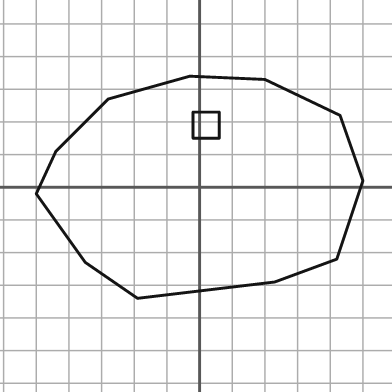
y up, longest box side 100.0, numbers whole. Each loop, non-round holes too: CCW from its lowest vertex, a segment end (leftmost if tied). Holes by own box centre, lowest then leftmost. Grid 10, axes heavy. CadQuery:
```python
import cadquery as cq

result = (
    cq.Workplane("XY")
    .moveTo(-19.0, -34.0)
    .lineTo(23.0, -29.0)
    .lineTo(42.0, -22.0)
    .lineTo(50.0, 2.0)
    .lineTo(43.0, 22.0)
    .lineTo(20.0, 33.0)
    .lineTo(-3.0, 34.0)
    .lineTo(-28.0, 27.0)
    .lineTo(-44.0, 11.0)
    .lineTo(-50.0, -2.0)
    .lineTo(-35.0, -23.0)
    .close()
    .moveTo(-2.0, 15.0)
    .lineTo(6.0, 15.0)
    .lineTo(6.0, 23.0)
    .lineTo(-2.0, 23.0)
    .close()
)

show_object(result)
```